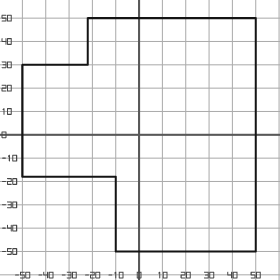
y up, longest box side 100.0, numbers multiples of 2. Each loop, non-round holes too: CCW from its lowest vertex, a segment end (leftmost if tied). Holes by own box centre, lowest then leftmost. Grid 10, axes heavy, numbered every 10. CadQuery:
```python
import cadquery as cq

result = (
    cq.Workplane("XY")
    .moveTo(-10.0, -50.0)
    .lineTo(50.0, -50.0)
    .lineTo(50.0, 50.0)
    .lineTo(-22.0, 50.0)
    .lineTo(-22.0, 30.0)
    .lineTo(-50.0, 30.0)
    .lineTo(-50.0, -18.0)
    .lineTo(-10.0, -18.0)
    .close()
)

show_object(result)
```